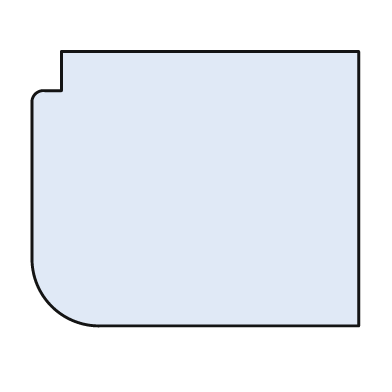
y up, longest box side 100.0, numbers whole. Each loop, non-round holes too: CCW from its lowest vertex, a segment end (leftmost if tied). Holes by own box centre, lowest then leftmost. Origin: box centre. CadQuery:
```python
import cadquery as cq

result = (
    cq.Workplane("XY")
    .moveTo(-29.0, -42.0)
    .lineTo(50.0, -42.0)
    .lineTo(50.0, 42.0)
    .lineTo(-41.0, 42.0)
    .lineTo(-41.0, 30.0)
    .lineTo(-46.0, 30.0)
    .threePointArc((-49.0, 29.0), (-50.0, 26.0))
    .lineTo(-50.0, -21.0)
    .threePointArc((-44.0, -36.0), (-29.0, -42.0))
    .close()
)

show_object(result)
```